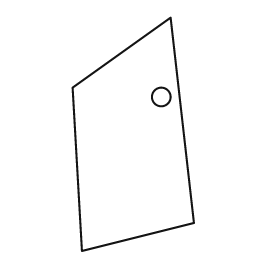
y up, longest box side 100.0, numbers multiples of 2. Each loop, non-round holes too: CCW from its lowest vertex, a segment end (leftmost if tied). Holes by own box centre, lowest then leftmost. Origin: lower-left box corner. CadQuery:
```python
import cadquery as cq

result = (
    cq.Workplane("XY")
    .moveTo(4.0, 0.0)
    .lineTo(52.0, 12.0)
    .lineTo(42.0, 100.0)
    .lineTo(0.0, 70.0)
    .close()
    .moveTo(38.0, 66.0)
    .circle(4.0)
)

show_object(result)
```